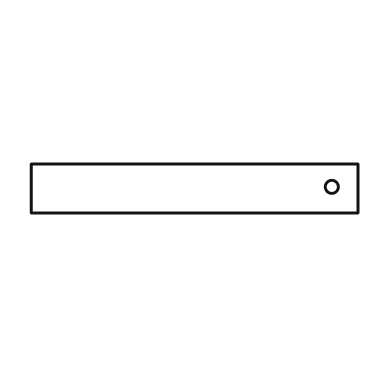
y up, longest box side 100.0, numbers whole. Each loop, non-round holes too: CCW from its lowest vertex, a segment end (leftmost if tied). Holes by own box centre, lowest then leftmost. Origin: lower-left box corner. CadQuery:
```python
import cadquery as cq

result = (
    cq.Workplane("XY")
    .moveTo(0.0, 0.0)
    .lineTo(100.0, 0.0)
    .lineTo(100.0, 15.0)
    .lineTo(0.0, 15.0)
    .close()
    .moveTo(92.0, 8.0)
    .circle(2.0)
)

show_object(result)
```